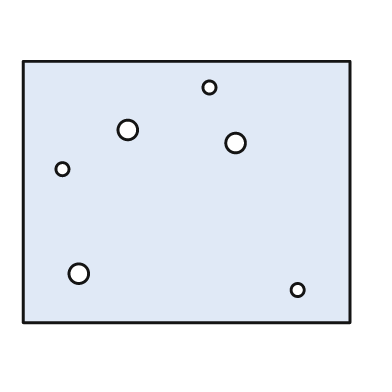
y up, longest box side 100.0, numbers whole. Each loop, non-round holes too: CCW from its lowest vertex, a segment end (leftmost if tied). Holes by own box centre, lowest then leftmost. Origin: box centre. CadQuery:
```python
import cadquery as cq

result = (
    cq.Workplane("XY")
    .moveTo(-50.0, -40.0)
    .lineTo(50.0, -40.0)
    .lineTo(50.0, 40.0)
    .lineTo(-50.0, 40.0)
    .close()
    .moveTo(34.0, -30.0)
    .circle(2.0)
    .moveTo(-33.0, -25.0)
    .circle(3.0)
    .moveTo(-38.0, 7.0)
    .circle(2.0)
    .moveTo(15.0, 15.0)
    .circle(3.0)
    .moveTo(-18.0, 19.0)
    .circle(3.0)
    .moveTo(7.0, 32.0)
    .circle(2.0)
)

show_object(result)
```